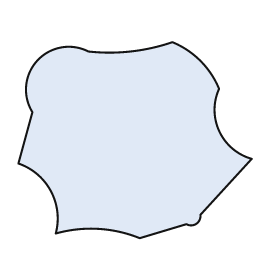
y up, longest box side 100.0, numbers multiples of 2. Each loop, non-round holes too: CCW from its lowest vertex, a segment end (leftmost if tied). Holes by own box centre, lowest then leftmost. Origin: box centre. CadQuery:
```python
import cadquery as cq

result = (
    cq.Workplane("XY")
    .moveTo(2.0, -42.0)
    .lineTo(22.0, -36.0)
    .threePointArc((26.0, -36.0), (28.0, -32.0))
    .lineTo(50.0, -8.0)
    .threePointArc((36.0, 4.0), (36.0, 22.0))
    .threePointArc((28.0, 34.0), (16.0, 42.0))
    .threePointArc((-2.0, 38.0), (-20.0, 38.0))
    .threePointArc((-42.0, 34.0), (-44.0, 12.0))
    .lineTo(-50.0, -10.0)
    .threePointArc((-36.0, -22.0), (-34.0, -40.0))
    .threePointArc((-16.0, -38.0), (2.0, -42.0))
    .close()
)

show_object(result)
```